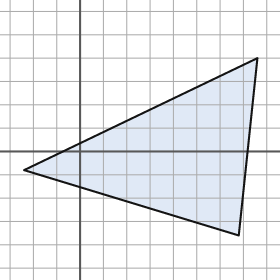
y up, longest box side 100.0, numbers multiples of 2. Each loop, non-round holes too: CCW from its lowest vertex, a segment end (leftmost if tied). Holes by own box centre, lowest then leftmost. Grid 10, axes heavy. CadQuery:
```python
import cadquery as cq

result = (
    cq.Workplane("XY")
    .moveTo(68.0, -36.0)
    .lineTo(76.0, 40.0)
    .lineTo(-24.0, -8.0)
    .close()
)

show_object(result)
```